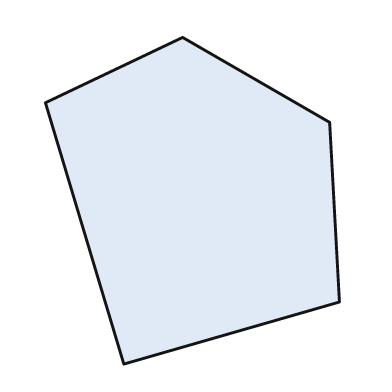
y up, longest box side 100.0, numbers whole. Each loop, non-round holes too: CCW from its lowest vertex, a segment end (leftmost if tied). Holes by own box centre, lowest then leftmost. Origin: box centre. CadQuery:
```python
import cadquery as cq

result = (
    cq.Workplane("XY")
    .moveTo(-21.0, -50.0)
    .lineTo(45.0, -31.0)
    .lineTo(42.0, 24.0)
    .lineTo(-3.0, 50.0)
    .lineTo(-45.0, 30.0)
    .close()
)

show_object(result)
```